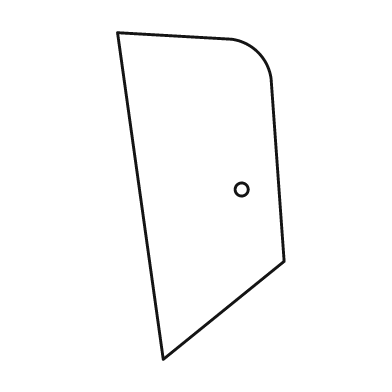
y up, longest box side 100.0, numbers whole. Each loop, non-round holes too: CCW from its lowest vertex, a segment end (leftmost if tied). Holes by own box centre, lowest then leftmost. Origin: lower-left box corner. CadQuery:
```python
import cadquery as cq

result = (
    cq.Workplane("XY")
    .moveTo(14.0, 0.0)
    .lineTo(51.0, 30.0)
    .lineTo(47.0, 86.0)
    .threePointArc((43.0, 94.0), (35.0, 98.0))
    .lineTo(0.0, 100.0)
    .close()
    .moveTo(38.0, 52.0)
    .circle(2.0)
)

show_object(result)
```